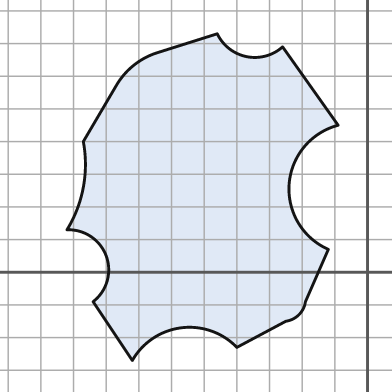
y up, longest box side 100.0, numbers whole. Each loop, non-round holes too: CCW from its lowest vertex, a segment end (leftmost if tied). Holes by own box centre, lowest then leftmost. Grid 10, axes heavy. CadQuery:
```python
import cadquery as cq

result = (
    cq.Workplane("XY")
    .moveTo(-72.0, -27.0)
    .threePointArc((-57.0, -17.0), (-40.0, -23.0))
    .lineTo(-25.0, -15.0)
    .threePointArc((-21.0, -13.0), (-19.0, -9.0))
    .lineTo(-12.0, 7.0)
    .threePointArc((-24.0, 27.0), (-9.0, 45.0))
    .lineTo(-26.0, 69.0)
    .threePointArc((-37.0, 66.0), (-46.0, 73.0))
    .lineTo(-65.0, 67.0)
    .threePointArc((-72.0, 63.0), (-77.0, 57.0))
    .lineTo(-87.0, 40.0)
    .threePointArc((-87.0, 26.0), (-92.0, 13.0))
    .threePointArc((-80.0, 5.0), (-84.0, -9.0))
    .close()
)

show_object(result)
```